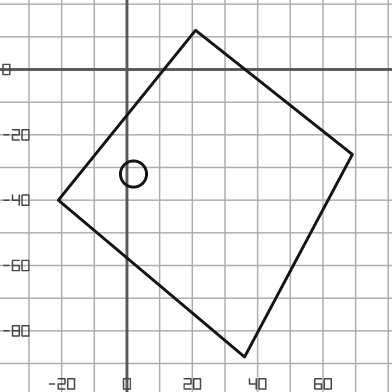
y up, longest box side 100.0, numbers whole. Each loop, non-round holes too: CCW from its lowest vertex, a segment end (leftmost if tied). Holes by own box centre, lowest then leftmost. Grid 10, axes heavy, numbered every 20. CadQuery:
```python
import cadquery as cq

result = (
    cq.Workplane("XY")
    .moveTo(36.0, -88.0)
    .lineTo(69.0, -26.0)
    .lineTo(21.0, 12.0)
    .lineTo(-21.0, -40.0)
    .close()
    .moveTo(2.0, -32.0)
    .circle(4.0)
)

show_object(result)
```